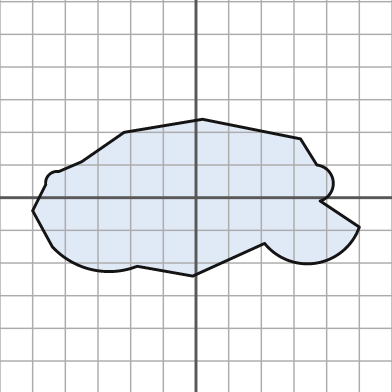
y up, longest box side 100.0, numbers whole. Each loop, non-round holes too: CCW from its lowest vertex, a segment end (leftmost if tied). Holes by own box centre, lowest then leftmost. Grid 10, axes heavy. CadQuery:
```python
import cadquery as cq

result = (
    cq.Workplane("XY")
    .moveTo(-1.0, -24.0)
    .lineTo(21.0, -14.0)
    .threePointArc((37.0, -20.0), (50.0, -9.0))
    .lineTo(38.0, -1.0)
    .threePointArc((42.0, 5.0), (37.0, 10.0))
    .lineTo(32.0, 18.0)
    .lineTo(2.0, 24.0)
    .lineTo(-22.0, 20.0)
    .lineTo(-35.0, 11.0)
    .lineTo(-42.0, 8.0)
    .threePointArc((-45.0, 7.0), (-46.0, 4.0))
    .lineTo(-50.0, -4.0)
    .lineTo(-44.0, -15.0)
    .threePointArc((-32.0, -22.0), (-18.0, -21.0))
    .close()
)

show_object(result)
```